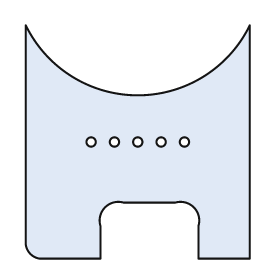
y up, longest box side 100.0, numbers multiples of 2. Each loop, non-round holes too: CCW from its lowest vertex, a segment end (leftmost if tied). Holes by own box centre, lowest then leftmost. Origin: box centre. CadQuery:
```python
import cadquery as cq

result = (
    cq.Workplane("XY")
    .moveTo(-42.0, -50.0)
    .lineTo(-16.0, -50.0)
    .lineTo(-16.0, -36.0)
    .threePointArc((-14.0, -28.0), (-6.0, -26.0))
    .lineTo(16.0, -26.0)
    .threePointArc((24.0, -28.0), (26.0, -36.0))
    .lineTo(26.0, -50.0)
    .lineTo(48.0, -50.0)
    .lineTo(48.0, 50.0)
    .threePointArc((0.0, 20.0), (-48.0, 50.0))
    .lineTo(-48.0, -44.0)
    .threePointArc((-46.0, -48.0), (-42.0, -50.0))
    .close()
    .moveTo(-20.0, 0.0)
    .circle(2.0)
    .moveTo(-10.0, 0.0)
    .circle(2.0)
    .moveTo(0.0, 0.0)
    .circle(2.0)
    .moveTo(10.0, 0.0)
    .circle(2.0)
    .moveTo(20.0, 0.0)
    .circle(2.0)
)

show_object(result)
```